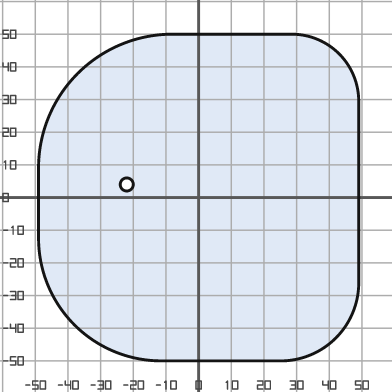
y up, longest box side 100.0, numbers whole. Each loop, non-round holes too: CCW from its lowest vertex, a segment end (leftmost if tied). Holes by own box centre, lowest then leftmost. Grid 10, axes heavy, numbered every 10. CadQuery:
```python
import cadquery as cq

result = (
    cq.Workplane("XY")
    .moveTo(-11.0, -50.0)
    .lineTo(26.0, -50.0)
    .threePointArc((42.0, -43.0), (49.0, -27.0))
    .lineTo(49.0, 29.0)
    .threePointArc((43.0, 44.0), (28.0, 50.0))
    .lineTo(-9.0, 50.0)
    .threePointArc((-37.0, 38.0), (-49.0, 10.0))
    .lineTo(-49.0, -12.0)
    .threePointArc((-38.0, -39.0), (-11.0, -50.0))
    .close()
    .moveTo(-22.0, 4.0)
    .circle(2.0)
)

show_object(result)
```